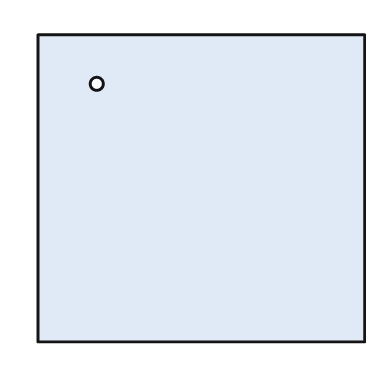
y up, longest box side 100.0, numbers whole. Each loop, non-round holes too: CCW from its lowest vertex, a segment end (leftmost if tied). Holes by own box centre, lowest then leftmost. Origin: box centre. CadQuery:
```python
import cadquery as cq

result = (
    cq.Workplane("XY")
    .moveTo(-50.0, -47.0)
    .lineTo(50.0, -47.0)
    .lineTo(50.0, 47.0)
    .lineTo(-50.0, 47.0)
    .close()
    .moveTo(-32.0, 32.0)
    .circle(2.0)
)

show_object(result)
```